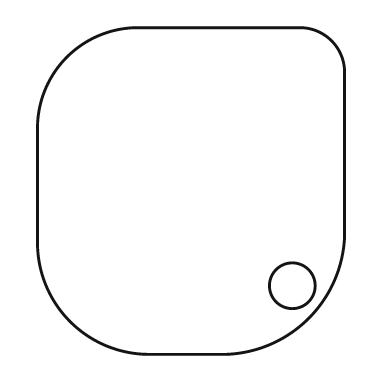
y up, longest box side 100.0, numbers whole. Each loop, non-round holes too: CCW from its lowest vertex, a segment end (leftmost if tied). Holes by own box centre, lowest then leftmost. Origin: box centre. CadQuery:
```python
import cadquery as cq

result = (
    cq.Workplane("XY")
    .moveTo(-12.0, -50.0)
    .lineTo(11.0, -50.0)
    .threePointArc((36.0, -39.0), (47.0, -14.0))
    .lineTo(47.0, 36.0)
    .threePointArc((43.0, 46.0), (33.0, 50.0))
    .lineTo(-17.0, 50.0)
    .threePointArc((-38.0, 41.0), (-47.0, 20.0))
    .lineTo(-47.0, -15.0)
    .threePointArc((-37.0, -40.0), (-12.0, -50.0))
    .close()
    .moveTo(31.0, -29.0)
    .circle(7.0)
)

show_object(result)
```